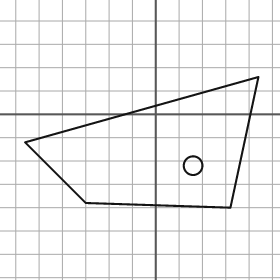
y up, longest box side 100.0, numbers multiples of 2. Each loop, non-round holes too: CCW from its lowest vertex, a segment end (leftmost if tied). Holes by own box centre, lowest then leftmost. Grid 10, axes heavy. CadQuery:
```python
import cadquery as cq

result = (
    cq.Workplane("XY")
    .moveTo(32.0, -40.0)
    .lineTo(44.0, 16.0)
    .lineTo(-56.0, -12.0)
    .lineTo(-30.0, -38.0)
    .close()
    .moveTo(16.0, -22.0)
    .circle(4.0)
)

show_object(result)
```